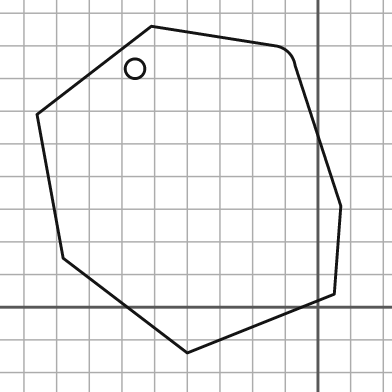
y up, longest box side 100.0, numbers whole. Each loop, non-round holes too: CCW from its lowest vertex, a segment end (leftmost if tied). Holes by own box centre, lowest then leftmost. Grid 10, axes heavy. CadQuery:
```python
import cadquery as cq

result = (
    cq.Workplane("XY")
    .moveTo(-40.0, -14.0)
    .lineTo(5.0, 4.0)
    .lineTo(7.0, 31.0)
    .lineTo(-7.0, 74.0)
    .threePointArc((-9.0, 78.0), (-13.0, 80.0))
    .lineTo(-51.0, 86.0)
    .lineTo(-86.0, 59.0)
    .lineTo(-78.0, 15.0)
    .close()
    .moveTo(-56.0, 73.0)
    .circle(3.0)
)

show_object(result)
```